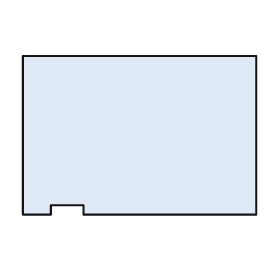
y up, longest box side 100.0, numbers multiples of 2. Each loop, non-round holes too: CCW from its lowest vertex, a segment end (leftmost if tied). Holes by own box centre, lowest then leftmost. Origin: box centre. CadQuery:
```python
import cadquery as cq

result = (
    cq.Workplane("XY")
    .moveTo(-50.0, -34.0)
    .lineTo(-38.0, -34.0)
    .lineTo(-38.0, -30.0)
    .lineTo(-24.0, -30.0)
    .lineTo(-24.0, -34.0)
    .lineTo(50.0, -34.0)
    .lineTo(50.0, 34.0)
    .lineTo(-50.0, 34.0)
    .close()
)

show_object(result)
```